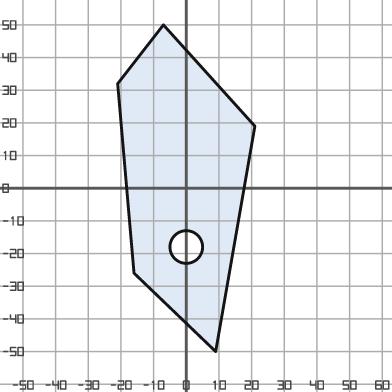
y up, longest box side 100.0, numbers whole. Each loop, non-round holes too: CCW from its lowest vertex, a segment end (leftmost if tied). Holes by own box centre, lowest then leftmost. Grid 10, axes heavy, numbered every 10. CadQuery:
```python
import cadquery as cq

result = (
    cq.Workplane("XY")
    .moveTo(9.0, -50.0)
    .lineTo(21.0, 19.0)
    .lineTo(-7.0, 50.0)
    .lineTo(-21.0, 32.0)
    .lineTo(-16.0, -26.0)
    .close()
    .moveTo(0.0, -18.0)
    .circle(5.0)
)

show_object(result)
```